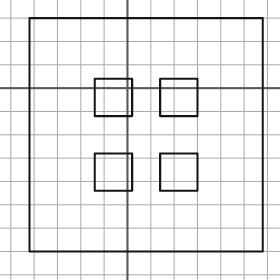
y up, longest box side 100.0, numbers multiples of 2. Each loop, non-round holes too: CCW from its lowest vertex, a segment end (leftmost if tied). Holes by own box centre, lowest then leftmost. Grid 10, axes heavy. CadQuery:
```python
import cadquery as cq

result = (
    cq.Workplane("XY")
    .moveTo(-42.0, -70.0)
    .lineTo(58.0, -70.0)
    .lineTo(58.0, 30.0)
    .lineTo(-42.0, 30.0)
    .close()
    .moveTo(-14.0, -44.0)
    .lineTo(2.0, -44.0)
    .lineTo(2.0, -28.0)
    .lineTo(-14.0, -28.0)
    .close()
    .moveTo(14.0, -44.0)
    .lineTo(30.0, -44.0)
    .lineTo(30.0, -28.0)
    .lineTo(14.0, -28.0)
    .close()
    .moveTo(-14.0, -12.0)
    .lineTo(2.0, -12.0)
    .lineTo(2.0, 4.0)
    .lineTo(-14.0, 4.0)
    .close()
    .moveTo(14.0, -12.0)
    .lineTo(30.0, -12.0)
    .lineTo(30.0, 4.0)
    .lineTo(14.0, 4.0)
    .close()
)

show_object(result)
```